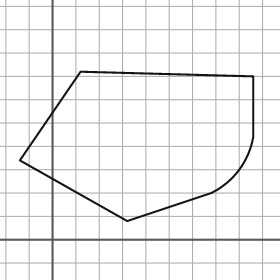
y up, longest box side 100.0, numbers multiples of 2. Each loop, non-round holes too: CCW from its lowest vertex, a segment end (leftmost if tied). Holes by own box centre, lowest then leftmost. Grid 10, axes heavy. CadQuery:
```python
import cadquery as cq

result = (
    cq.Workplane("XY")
    .moveTo(32.0, 8.0)
    .lineTo(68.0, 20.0)
    .threePointArc((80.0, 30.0), (86.0, 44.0))
    .lineTo(86.0, 70.0)
    .lineTo(12.0, 72.0)
    .lineTo(-14.0, 34.0)
    .close()
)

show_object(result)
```